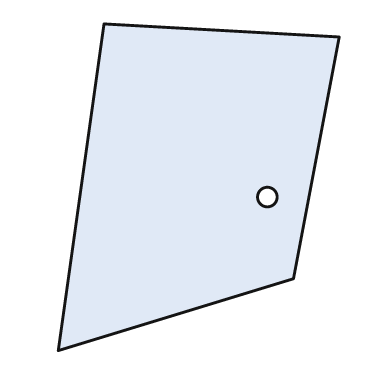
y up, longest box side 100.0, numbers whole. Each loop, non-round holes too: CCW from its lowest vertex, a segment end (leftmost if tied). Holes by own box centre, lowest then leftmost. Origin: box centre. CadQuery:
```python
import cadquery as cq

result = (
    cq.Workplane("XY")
    .moveTo(-43.0, -50.0)
    .lineTo(29.0, -28.0)
    .lineTo(43.0, 46.0)
    .lineTo(-29.0, 50.0)
    .close()
    .moveTo(21.0, -3.0)
    .circle(3.0)
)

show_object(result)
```